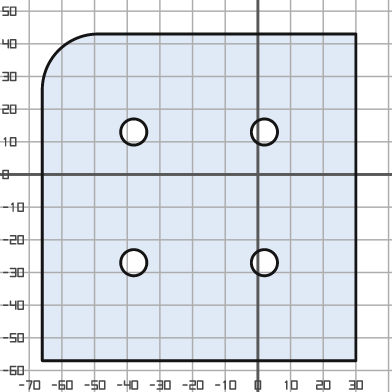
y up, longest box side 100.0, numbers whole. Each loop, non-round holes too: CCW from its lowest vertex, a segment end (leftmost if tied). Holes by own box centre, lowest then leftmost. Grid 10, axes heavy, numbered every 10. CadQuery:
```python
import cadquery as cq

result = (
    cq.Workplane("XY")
    .moveTo(-66.0, -57.0)
    .lineTo(30.0, -57.0)
    .lineTo(30.0, 43.0)
    .lineTo(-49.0, 43.0)
    .threePointArc((-61.0, 38.0), (-66.0, 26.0))
    .close()
    .moveTo(-38.0, -27.0)
    .circle(4.0)
    .moveTo(2.0, -27.0)
    .circle(4.0)
    .moveTo(-38.0, 13.0)
    .circle(4.0)
    .moveTo(2.0, 13.0)
    .circle(4.0)
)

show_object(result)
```